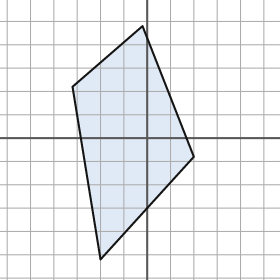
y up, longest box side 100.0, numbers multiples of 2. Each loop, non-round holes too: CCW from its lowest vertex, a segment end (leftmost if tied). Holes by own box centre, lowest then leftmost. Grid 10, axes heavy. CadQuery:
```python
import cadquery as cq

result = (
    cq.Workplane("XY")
    .moveTo(-20.0, -52.0)
    .lineTo(20.0, -8.0)
    .lineTo(-2.0, 48.0)
    .lineTo(-32.0, 22.0)
    .close()
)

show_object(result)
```